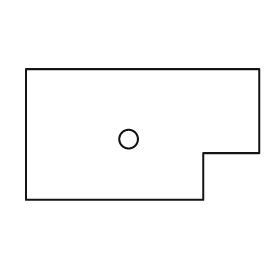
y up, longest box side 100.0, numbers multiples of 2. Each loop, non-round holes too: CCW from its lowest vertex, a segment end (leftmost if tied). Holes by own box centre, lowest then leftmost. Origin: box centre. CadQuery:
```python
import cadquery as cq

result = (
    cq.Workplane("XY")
    .moveTo(-50.0, -28.0)
    .lineTo(26.0, -28.0)
    .lineTo(26.0, -8.0)
    .lineTo(50.0, -8.0)
    .lineTo(50.0, 28.0)
    .lineTo(-50.0, 28.0)
    .close()
    .moveTo(-6.0, -2.0)
    .circle(4.0)
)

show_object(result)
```